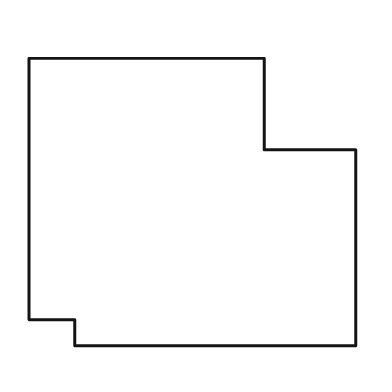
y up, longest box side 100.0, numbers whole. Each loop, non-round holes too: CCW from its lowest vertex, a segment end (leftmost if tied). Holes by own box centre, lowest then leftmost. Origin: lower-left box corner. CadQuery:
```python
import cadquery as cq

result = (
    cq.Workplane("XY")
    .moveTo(14.0, 0.0)
    .lineTo(100.0, 0.0)
    .lineTo(100.0, 60.0)
    .lineTo(72.0, 60.0)
    .lineTo(72.0, 88.0)
    .lineTo(0.0, 88.0)
    .lineTo(0.0, 8.0)
    .lineTo(14.0, 8.0)
    .close()
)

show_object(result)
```